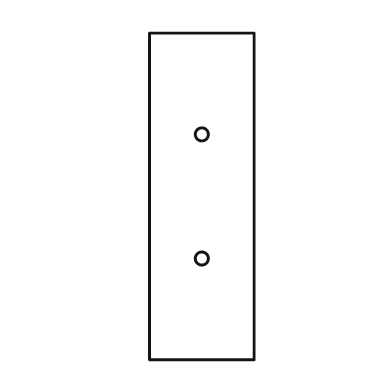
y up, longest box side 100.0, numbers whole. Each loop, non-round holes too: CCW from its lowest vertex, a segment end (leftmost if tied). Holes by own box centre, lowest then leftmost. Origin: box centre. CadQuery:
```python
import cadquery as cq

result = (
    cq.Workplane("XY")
    .moveTo(-16.0, -50.0)
    .lineTo(16.0, -50.0)
    .lineTo(16.0, 50.0)
    .lineTo(-16.0, 50.0)
    .close()
    .moveTo(0.0, -19.0)
    .circle(2.0)
    .moveTo(0.0, 19.0)
    .circle(2.0)
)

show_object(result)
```